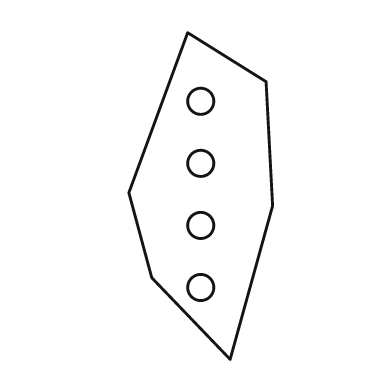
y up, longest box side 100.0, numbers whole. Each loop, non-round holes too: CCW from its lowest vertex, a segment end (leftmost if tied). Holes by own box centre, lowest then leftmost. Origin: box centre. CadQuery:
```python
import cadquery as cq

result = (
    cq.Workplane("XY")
    .moveTo(9.0, -50.0)
    .lineTo(22.0, -3.0)
    .lineTo(20.0, 35.0)
    .lineTo(-4.0, 50.0)
    .lineTo(-22.0, 1.0)
    .lineTo(-15.0, -25.0)
    .close()
    .moveTo(0.0, -28.0)
    .circle(4.0)
    .moveTo(0.0, -9.0)
    .circle(4.0)
    .moveTo(0.0, 10.0)
    .circle(4.0)
    .moveTo(0.0, 29.0)
    .circle(4.0)
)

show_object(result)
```